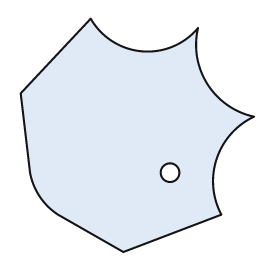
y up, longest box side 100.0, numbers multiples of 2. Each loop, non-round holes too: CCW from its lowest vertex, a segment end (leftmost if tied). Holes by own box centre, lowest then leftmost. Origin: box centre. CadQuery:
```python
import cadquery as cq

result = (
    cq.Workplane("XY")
    .moveTo(-6.0, -50.0)
    .lineTo(36.0, -34.0)
    .threePointArc((34.0, -10.0), (50.0, 8.0))
    .threePointArc((30.0, 22.0), (26.0, 46.0))
    .threePointArc((2.0, 36.0), (-20.0, 50.0))
    .lineTo(-50.0, 18.0)
    .lineTo(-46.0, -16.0)
    .threePointArc((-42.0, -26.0), (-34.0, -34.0))
    .close()
    .moveTo(14.0, -16.0)
    .circle(4.0)
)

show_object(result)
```